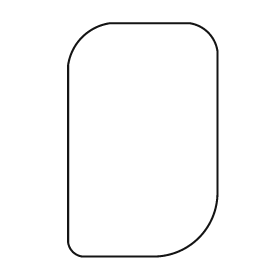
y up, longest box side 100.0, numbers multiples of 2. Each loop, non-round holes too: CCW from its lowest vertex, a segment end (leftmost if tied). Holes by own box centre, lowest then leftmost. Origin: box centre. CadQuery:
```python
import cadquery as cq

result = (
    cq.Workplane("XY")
    .moveTo(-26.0, -50.0)
    .lineTo(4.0, -50.0)
    .threePointArc((24.0, -42.0), (32.0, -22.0))
    .lineTo(32.0, 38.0)
    .threePointArc((28.0, 46.0), (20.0, 50.0))
    .lineTo(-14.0, 50.0)
    .threePointArc((-26.0, 44.0), (-32.0, 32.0))
    .lineTo(-32.0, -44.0)
    .threePointArc((-30.0, -48.0), (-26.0, -50.0))
    .close()
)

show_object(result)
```